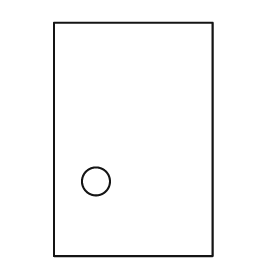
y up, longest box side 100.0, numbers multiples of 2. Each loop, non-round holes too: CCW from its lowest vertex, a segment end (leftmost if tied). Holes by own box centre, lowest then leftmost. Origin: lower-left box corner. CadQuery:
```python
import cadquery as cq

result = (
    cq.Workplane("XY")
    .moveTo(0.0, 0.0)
    .lineTo(68.0, 0.0)
    .lineTo(68.0, 100.0)
    .lineTo(0.0, 100.0)
    .close()
    .moveTo(18.0, 32.0)
    .circle(6.0)
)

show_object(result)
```